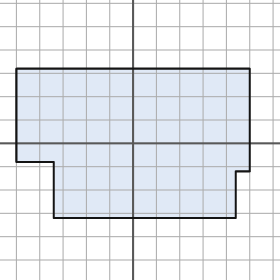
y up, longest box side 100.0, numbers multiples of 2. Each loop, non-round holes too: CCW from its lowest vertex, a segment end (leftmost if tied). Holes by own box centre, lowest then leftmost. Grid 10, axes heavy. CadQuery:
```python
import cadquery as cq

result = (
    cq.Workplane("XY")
    .moveTo(-34.0, -32.0)
    .lineTo(44.0, -32.0)
    .lineTo(44.0, -12.0)
    .lineTo(50.0, -12.0)
    .lineTo(50.0, 32.0)
    .lineTo(-50.0, 32.0)
    .lineTo(-50.0, -8.0)
    .lineTo(-34.0, -8.0)
    .close()
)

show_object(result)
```